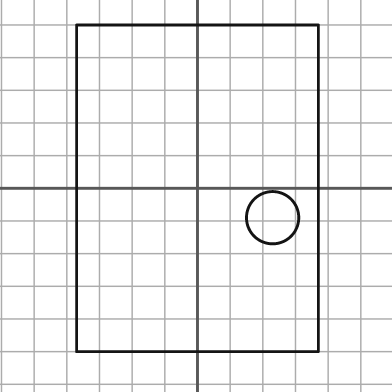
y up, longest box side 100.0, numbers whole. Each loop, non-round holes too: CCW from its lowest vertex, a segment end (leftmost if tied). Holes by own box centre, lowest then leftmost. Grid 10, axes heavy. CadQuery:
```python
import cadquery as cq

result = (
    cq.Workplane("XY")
    .moveTo(-37.0, -50.0)
    .lineTo(37.0, -50.0)
    .lineTo(37.0, 50.0)
    .lineTo(-37.0, 50.0)
    .close()
    .moveTo(23.0, -9.0)
    .circle(8.0)
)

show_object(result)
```